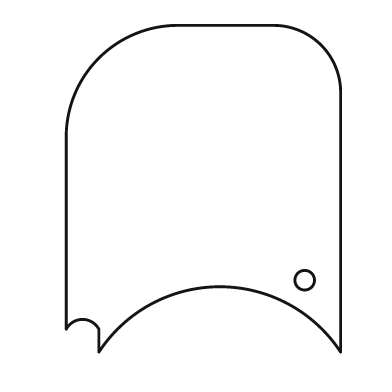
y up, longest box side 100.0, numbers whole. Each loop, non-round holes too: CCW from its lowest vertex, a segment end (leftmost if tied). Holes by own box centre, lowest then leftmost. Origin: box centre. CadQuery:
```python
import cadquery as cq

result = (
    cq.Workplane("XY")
    .moveTo(-32.0, -50.0)
    .threePointArc((5.0, -30.0), (42.0, -50.0))
    .lineTo(42.0, 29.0)
    .threePointArc((36.0, 44.0), (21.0, 50.0))
    .lineTo(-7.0, 50.0)
    .threePointArc((-32.0, 40.0), (-42.0, 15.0))
    .lineTo(-42.0, -43.0)
    .threePointArc((-37.0, -40.0), (-32.0, -43.0))
    .close()
    .moveTo(31.0, -28.0)
    .circle(3.0)
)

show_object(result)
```